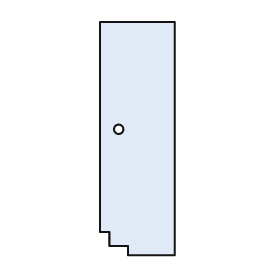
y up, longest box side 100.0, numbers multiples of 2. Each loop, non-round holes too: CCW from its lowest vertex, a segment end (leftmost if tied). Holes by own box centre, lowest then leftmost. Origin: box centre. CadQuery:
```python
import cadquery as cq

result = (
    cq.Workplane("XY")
    .moveTo(-4.0, -50.0)
    .lineTo(16.0, -50.0)
    .lineTo(16.0, 50.0)
    .lineTo(-16.0, 50.0)
    .lineTo(-16.0, -40.0)
    .lineTo(-12.0, -40.0)
    .lineTo(-12.0, -46.0)
    .lineTo(-4.0, -46.0)
    .close()
    .moveTo(-8.0, 4.0)
    .circle(2.0)
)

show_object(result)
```